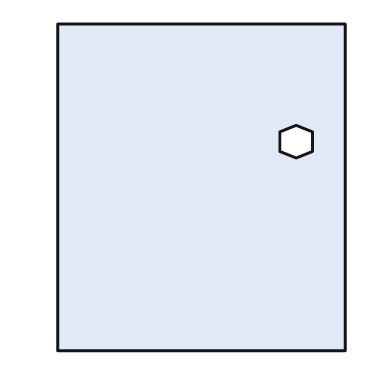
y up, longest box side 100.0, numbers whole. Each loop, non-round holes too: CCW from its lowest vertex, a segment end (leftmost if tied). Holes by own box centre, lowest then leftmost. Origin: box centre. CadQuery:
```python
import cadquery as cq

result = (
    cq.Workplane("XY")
    .moveTo(-44.0, -50.0)
    .lineTo(44.0, -50.0)
    .lineTo(44.0, 50.0)
    .lineTo(-44.0, 50.0)
    .close()
    .moveTo(29.0, 9.0)
    .lineTo(34.0, 11.0)
    .lineTo(34.0, 17.0)
    .lineTo(29.0, 19.0)
    .lineTo(24.0, 17.0)
    .lineTo(24.0, 11.0)
    .close()
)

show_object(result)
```